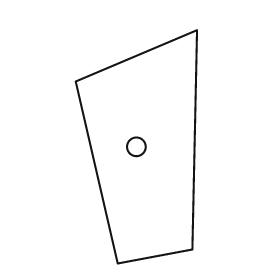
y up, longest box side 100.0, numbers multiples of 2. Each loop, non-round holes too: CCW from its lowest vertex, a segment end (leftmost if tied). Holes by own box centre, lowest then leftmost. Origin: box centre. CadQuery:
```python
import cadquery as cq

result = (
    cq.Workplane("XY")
    .moveTo(-8.0, -50.0)
    .lineTo(24.0, -44.0)
    .lineTo(26.0, 50.0)
    .lineTo(-26.0, 28.0)
    .close()
    .moveTo(0.0, 0.0)
    .circle(4.0)
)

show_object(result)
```